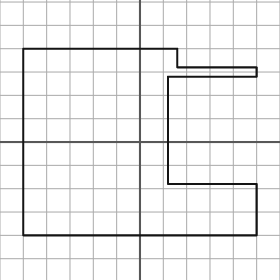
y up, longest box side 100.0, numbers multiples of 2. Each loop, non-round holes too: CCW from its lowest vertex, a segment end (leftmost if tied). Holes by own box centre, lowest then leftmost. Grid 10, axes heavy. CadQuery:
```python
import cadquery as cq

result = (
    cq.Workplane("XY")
    .moveTo(-50.0, -40.0)
    .lineTo(50.0, -40.0)
    .lineTo(50.0, -18.0)
    .lineTo(12.0, -18.0)
    .lineTo(12.0, 28.0)
    .lineTo(50.0, 28.0)
    .lineTo(50.0, 32.0)
    .lineTo(16.0, 32.0)
    .lineTo(16.0, 40.0)
    .lineTo(-50.0, 40.0)
    .close()
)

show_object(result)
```